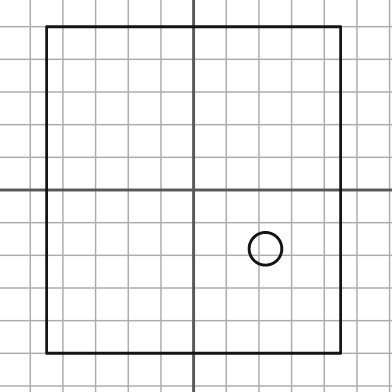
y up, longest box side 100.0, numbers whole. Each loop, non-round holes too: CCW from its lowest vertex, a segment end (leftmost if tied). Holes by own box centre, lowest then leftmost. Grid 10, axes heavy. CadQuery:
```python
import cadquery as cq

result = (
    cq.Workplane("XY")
    .moveTo(-45.0, -50.0)
    .lineTo(45.0, -50.0)
    .lineTo(45.0, 50.0)
    .lineTo(-45.0, 50.0)
    .close()
    .moveTo(22.0, -18.0)
    .circle(5.0)
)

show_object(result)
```